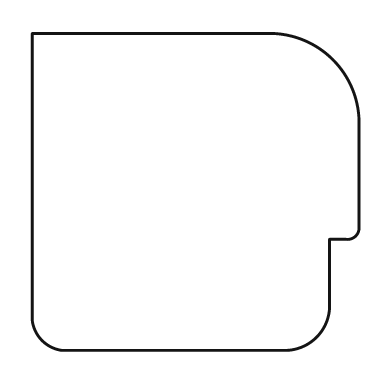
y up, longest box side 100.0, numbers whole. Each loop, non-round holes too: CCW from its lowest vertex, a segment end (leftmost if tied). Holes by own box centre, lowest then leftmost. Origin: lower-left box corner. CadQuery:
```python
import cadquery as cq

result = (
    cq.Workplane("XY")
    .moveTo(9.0, 0.0)
    .lineTo(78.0, 0.0)
    .threePointArc((87.0, 4.0), (91.0, 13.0))
    .lineTo(91.0, 34.0)
    .lineTo(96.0, 34.0)
    .threePointArc((99.0, 35.0), (100.0, 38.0))
    .lineTo(100.0, 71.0)
    .threePointArc((92.0, 89.0), (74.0, 97.0))
    .lineTo(0.0, 97.0)
    .lineTo(0.0, 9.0)
    .threePointArc((3.0, 3.0), (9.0, 0.0))
    .close()
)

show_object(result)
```